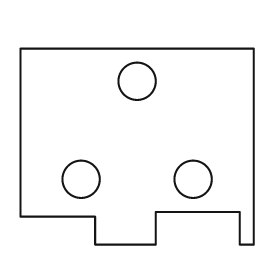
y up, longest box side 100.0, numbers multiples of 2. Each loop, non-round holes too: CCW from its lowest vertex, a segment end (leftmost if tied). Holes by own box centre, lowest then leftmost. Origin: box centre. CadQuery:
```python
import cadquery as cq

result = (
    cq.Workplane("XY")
    .moveTo(-18.0, -42.0)
    .lineTo(8.0, -42.0)
    .lineTo(8.0, -28.0)
    .lineTo(44.0, -28.0)
    .lineTo(44.0, -42.0)
    .lineTo(50.0, -42.0)
    .lineTo(50.0, 42.0)
    .lineTo(-50.0, 42.0)
    .lineTo(-50.0, -30.0)
    .lineTo(-18.0, -30.0)
    .close()
    .moveTo(-24.0, -14.0)
    .circle(8.0)
    .moveTo(24.0, -14.0)
    .circle(8.0)
    .moveTo(0.0, 28.0)
    .circle(8.0)
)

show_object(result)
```